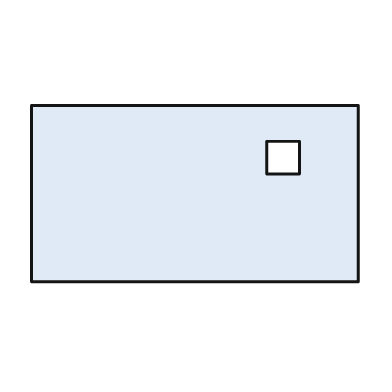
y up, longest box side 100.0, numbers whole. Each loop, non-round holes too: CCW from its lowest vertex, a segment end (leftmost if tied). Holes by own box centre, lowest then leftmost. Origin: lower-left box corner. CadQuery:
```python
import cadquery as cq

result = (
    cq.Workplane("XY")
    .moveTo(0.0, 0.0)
    .lineTo(100.0, 0.0)
    .lineTo(100.0, 54.0)
    .lineTo(0.0, 54.0)
    .close()
    .moveTo(72.0, 33.0)
    .lineTo(82.0, 33.0)
    .lineTo(82.0, 43.0)
    .lineTo(72.0, 43.0)
    .close()
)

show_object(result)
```